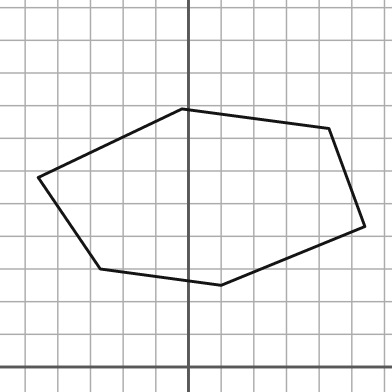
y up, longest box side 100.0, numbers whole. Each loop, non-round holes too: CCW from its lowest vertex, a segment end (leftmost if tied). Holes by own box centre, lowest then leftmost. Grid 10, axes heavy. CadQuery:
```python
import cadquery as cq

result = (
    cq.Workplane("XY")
    .moveTo(10.0, 25.0)
    .lineTo(54.0, 43.0)
    .lineTo(43.0, 73.0)
    .lineTo(-2.0, 79.0)
    .lineTo(-46.0, 58.0)
    .lineTo(-27.0, 30.0)
    .close()
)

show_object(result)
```